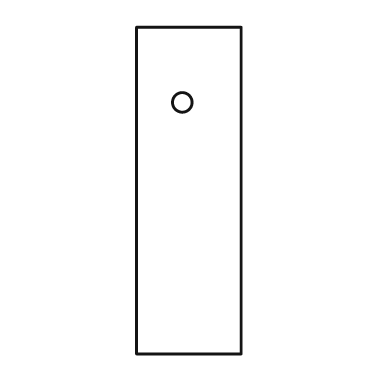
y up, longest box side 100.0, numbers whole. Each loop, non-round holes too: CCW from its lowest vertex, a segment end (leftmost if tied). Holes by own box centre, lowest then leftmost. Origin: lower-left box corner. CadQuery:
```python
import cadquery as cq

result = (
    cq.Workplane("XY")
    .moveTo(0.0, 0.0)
    .lineTo(32.0, 0.0)
    .lineTo(32.0, 100.0)
    .lineTo(0.0, 100.0)
    .close()
    .moveTo(14.0, 77.0)
    .circle(3.0)
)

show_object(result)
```